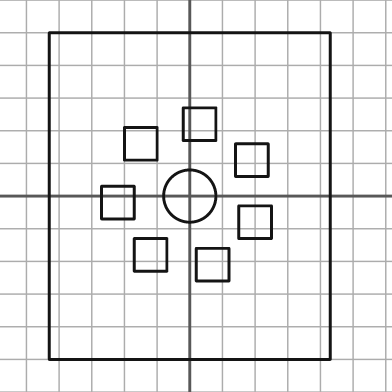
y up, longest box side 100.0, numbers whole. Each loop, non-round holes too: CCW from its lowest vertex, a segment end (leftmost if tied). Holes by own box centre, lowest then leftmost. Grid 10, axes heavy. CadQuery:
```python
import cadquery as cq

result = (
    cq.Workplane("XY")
    .moveTo(-43.0, -50.0)
    .lineTo(43.0, -50.0)
    .lineTo(43.0, 50.0)
    .lineTo(-43.0, 50.0)
    .close()
    .moveTo(2.0, -26.0)
    .lineTo(12.0, -26.0)
    .lineTo(12.0, -16.0)
    .lineTo(2.0, -16.0)
    .close()
    .moveTo(-17.0, -23.0)
    .lineTo(-7.0, -23.0)
    .lineTo(-7.0, -13.0)
    .lineTo(-17.0, -13.0)
    .close()
    .moveTo(15.0, -13.0)
    .lineTo(25.0, -13.0)
    .lineTo(25.0, -3.0)
    .lineTo(15.0, -3.0)
    .close()
    .moveTo(-27.0, -7.0)
    .lineTo(-17.0, -7.0)
    .lineTo(-17.0, 3.0)
    .lineTo(-27.0, 3.0)
    .close()
    .moveTo(0.0, 0.0)
    .circle(8.0)
    .moveTo(14.0, 6.0)
    .lineTo(24.0, 6.0)
    .lineTo(24.0, 16.0)
    .lineTo(14.0, 16.0)
    .close()
    .moveTo(-20.0, 11.0)
    .lineTo(-10.0, 11.0)
    .lineTo(-10.0, 21.0)
    .lineTo(-20.0, 21.0)
    .close()
    .moveTo(-2.0, 17.0)
    .lineTo(8.0, 17.0)
    .lineTo(8.0, 27.0)
    .lineTo(-2.0, 27.0)
    .close()
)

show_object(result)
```